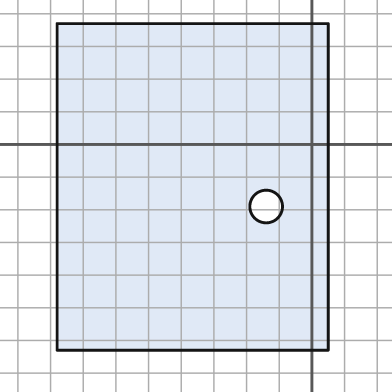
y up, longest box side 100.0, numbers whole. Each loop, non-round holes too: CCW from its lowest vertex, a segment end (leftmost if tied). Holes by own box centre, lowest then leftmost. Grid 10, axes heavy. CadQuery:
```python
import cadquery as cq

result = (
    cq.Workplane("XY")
    .moveTo(-78.0, -63.0)
    .lineTo(5.0, -63.0)
    .lineTo(5.0, 37.0)
    .lineTo(-78.0, 37.0)
    .close()
    .moveTo(-14.0, -19.0)
    .circle(5.0)
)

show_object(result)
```